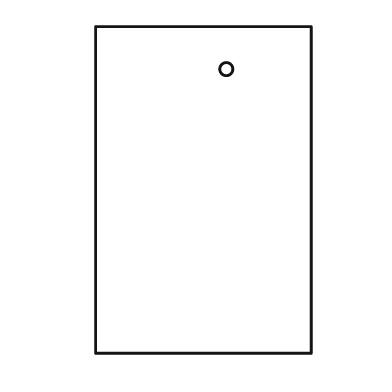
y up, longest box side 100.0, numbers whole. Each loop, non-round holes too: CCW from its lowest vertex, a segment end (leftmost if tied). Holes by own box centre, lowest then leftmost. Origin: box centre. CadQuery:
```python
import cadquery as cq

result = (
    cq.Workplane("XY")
    .moveTo(-33.0, -50.0)
    .lineTo(33.0, -50.0)
    .lineTo(33.0, 50.0)
    .lineTo(-33.0, 50.0)
    .close()
    .moveTo(7.0, 37.0)
    .circle(2.0)
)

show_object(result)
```